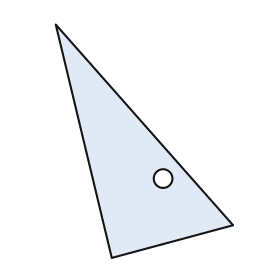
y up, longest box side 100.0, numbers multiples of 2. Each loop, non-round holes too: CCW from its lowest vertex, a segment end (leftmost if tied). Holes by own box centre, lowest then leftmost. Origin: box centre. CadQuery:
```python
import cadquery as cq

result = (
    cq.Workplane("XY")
    .moveTo(-14.0, -50.0)
    .lineTo(38.0, -36.0)
    .lineTo(-38.0, 50.0)
    .close()
    .moveTo(8.0, -16.0)
    .circle(4.0)
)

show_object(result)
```